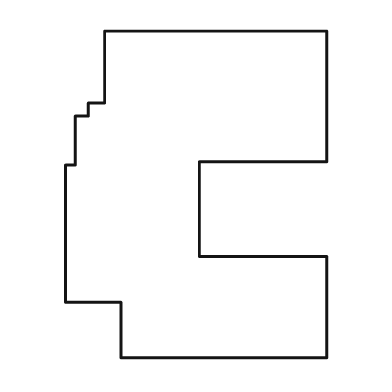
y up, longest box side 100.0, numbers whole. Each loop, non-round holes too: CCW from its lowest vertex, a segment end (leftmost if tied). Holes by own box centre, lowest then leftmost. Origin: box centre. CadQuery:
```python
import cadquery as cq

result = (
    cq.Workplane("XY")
    .moveTo(-23.0, -50.0)
    .lineTo(40.0, -50.0)
    .lineTo(40.0, -19.0)
    .lineTo(1.0, -19.0)
    .lineTo(1.0, 10.0)
    .lineTo(40.0, 10.0)
    .lineTo(40.0, 50.0)
    .lineTo(-28.0, 50.0)
    .lineTo(-28.0, 28.0)
    .lineTo(-33.0, 28.0)
    .lineTo(-33.0, 24.0)
    .lineTo(-37.0, 24.0)
    .lineTo(-37.0, 9.0)
    .lineTo(-40.0, 9.0)
    .lineTo(-40.0, -33.0)
    .lineTo(-23.0, -33.0)
    .close()
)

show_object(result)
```